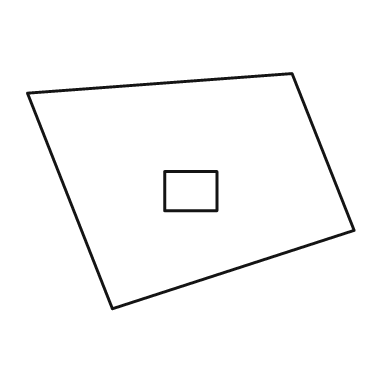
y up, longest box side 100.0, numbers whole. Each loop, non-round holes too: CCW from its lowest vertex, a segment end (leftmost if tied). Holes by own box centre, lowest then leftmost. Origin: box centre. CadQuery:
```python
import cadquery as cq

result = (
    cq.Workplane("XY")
    .moveTo(-24.0, -36.0)
    .lineTo(50.0, -12.0)
    .lineTo(31.0, 36.0)
    .lineTo(-50.0, 30.0)
    .close()
    .moveTo(-8.0, -6.0)
    .lineTo(8.0, -6.0)
    .lineTo(8.0, 6.0)
    .lineTo(-8.0, 6.0)
    .close()
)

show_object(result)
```